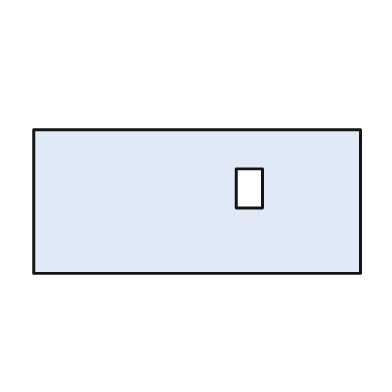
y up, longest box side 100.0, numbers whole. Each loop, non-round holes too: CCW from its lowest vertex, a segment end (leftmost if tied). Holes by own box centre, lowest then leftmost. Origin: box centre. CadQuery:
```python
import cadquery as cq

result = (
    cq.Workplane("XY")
    .moveTo(-50.0, -22.0)
    .lineTo(50.0, -22.0)
    .lineTo(50.0, 22.0)
    .lineTo(-50.0, 22.0)
    .close()
    .moveTo(12.0, -2.0)
    .lineTo(20.0, -2.0)
    .lineTo(20.0, 10.0)
    .lineTo(12.0, 10.0)
    .close()
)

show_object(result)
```